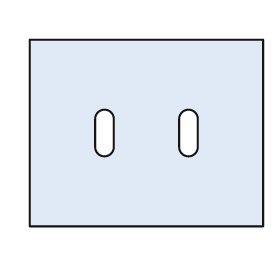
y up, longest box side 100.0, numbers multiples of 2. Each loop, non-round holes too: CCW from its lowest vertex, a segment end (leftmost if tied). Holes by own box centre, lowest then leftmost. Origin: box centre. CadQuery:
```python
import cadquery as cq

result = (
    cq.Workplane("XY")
    .moveTo(-50.0, -40.0)
    .lineTo(50.0, -40.0)
    .lineTo(50.0, 40.0)
    .lineTo(-50.0, 40.0)
    .close()
    .moveTo(-22.0, -6.0)
    .threePointArc((-18.0, -10.0), (-14.0, -6.0))
    .lineTo(-14.0, 6.0)
    .threePointArc((-18.0, 10.0), (-22.0, 6.0))
    .close()
    .moveTo(14.0, -6.0)
    .threePointArc((18.0, -10.0), (22.0, -6.0))
    .lineTo(22.0, 6.0)
    .threePointArc((18.0, 10.0), (14.0, 6.0))
    .close()
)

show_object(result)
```